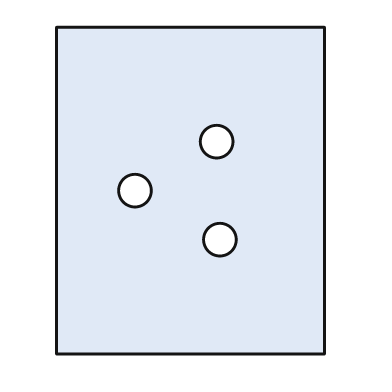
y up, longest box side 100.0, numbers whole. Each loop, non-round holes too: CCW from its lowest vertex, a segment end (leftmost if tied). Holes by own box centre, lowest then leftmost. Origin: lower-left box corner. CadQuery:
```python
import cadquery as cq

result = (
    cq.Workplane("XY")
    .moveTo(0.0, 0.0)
    .lineTo(82.0, 0.0)
    .lineTo(82.0, 100.0)
    .lineTo(0.0, 100.0)
    .close()
    .moveTo(50.0, 35.0)
    .circle(5.0)
    .moveTo(24.0, 50.0)
    .circle(5.0)
    .moveTo(49.0, 65.0)
    .circle(5.0)
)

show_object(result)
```